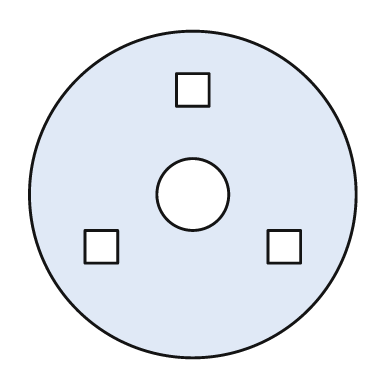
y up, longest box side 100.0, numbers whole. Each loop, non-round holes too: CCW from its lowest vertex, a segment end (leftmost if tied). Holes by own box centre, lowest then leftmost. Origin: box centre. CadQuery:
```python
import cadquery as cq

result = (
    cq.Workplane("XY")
    .moveTo(0.0, 0.0)
    .circle(50.0)
    .moveTo(-33.0, -21.0)
    .lineTo(-23.0, -21.0)
    .lineTo(-23.0, -11.0)
    .lineTo(-33.0, -11.0)
    .close()
    .moveTo(23.0, -21.0)
    .lineTo(33.0, -21.0)
    .lineTo(33.0, -11.0)
    .lineTo(23.0, -11.0)
    .close()
    .moveTo(0.0, 0.0)
    .circle(11.0)
    .moveTo(-5.0, 27.0)
    .lineTo(5.0, 27.0)
    .lineTo(5.0, 37.0)
    .lineTo(-5.0, 37.0)
    .close()
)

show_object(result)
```